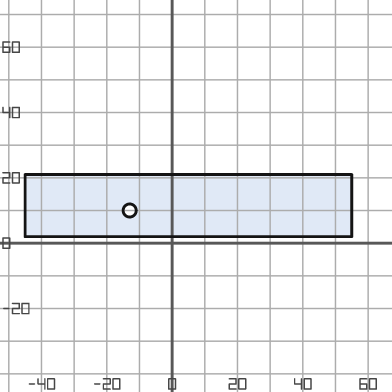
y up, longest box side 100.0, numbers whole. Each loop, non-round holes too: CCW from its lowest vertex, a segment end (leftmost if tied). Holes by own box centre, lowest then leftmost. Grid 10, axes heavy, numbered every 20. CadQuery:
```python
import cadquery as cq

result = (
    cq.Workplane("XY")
    .moveTo(-45.0, 2.0)
    .lineTo(55.0, 2.0)
    .lineTo(55.0, 21.0)
    .lineTo(-45.0, 21.0)
    .close()
    .moveTo(-13.0, 10.0)
    .circle(2.0)
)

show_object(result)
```